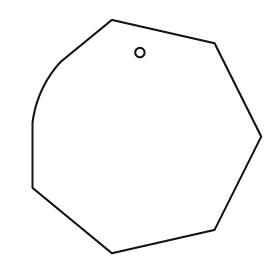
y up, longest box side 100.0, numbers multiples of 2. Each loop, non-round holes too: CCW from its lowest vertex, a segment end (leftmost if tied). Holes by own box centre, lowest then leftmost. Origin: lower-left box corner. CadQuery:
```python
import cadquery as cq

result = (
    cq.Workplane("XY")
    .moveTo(34.0, 0.0)
    .lineTo(78.0, 10.0)
    .lineTo(98.0, 50.0)
    .lineTo(78.0, 90.0)
    .lineTo(34.0, 100.0)
    .lineTo(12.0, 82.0)
    .threePointArc((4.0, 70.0), (0.0, 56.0))
    .lineTo(0.0, 28.0)
    .close()
    .moveTo(46.0, 86.0)
    .circle(2.0)
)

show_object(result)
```